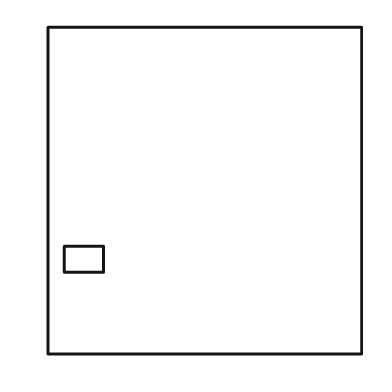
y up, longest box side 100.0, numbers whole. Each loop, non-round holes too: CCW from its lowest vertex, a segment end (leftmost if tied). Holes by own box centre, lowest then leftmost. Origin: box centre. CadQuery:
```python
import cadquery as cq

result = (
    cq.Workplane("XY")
    .moveTo(-48.0, -50.0)
    .lineTo(48.0, -50.0)
    .lineTo(48.0, 50.0)
    .lineTo(-48.0, 50.0)
    .close()
    .moveTo(-43.0, -25.0)
    .lineTo(-31.0, -25.0)
    .lineTo(-31.0, -17.0)
    .lineTo(-43.0, -17.0)
    .close()
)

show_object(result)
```